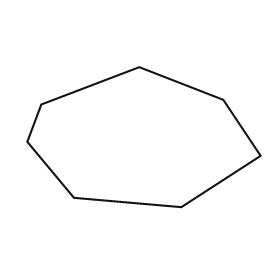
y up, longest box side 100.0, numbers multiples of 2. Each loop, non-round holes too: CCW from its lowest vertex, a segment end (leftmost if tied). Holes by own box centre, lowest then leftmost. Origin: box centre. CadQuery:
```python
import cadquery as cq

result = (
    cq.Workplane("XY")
    .moveTo(16.0, -30.0)
    .lineTo(50.0, -8.0)
    .lineTo(34.0, 16.0)
    .lineTo(-2.0, 30.0)
    .lineTo(-44.0, 14.0)
    .lineTo(-50.0, -2.0)
    .lineTo(-30.0, -26.0)
    .close()
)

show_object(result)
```